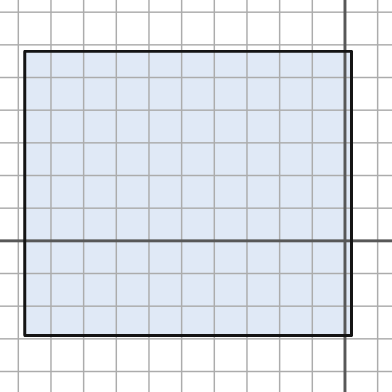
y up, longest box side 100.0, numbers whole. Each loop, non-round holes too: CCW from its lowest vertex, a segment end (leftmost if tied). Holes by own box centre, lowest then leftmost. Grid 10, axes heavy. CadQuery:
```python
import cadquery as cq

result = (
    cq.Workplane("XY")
    .moveTo(-98.0, -29.0)
    .lineTo(2.0, -29.0)
    .lineTo(2.0, 58.0)
    .lineTo(-98.0, 58.0)
    .close()
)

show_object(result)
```